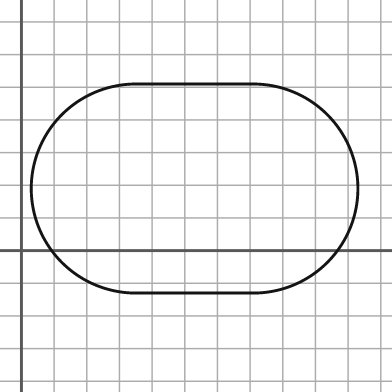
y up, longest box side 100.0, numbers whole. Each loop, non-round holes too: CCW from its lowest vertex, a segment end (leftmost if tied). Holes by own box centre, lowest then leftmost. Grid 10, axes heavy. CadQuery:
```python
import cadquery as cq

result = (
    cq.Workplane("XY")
    .moveTo(35.0, -13.0)
    .lineTo(71.0, -13.0)
    .threePointArc((103.0, 19.0), (71.0, 51.0))
    .lineTo(35.0, 51.0)
    .threePointArc((3.0, 19.0), (35.0, -13.0))
    .close()
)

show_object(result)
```